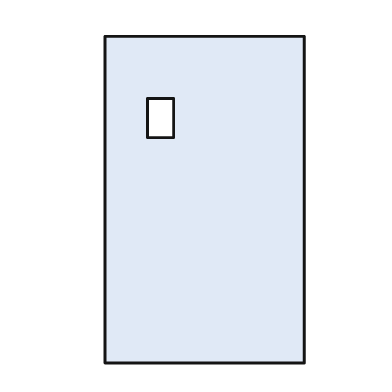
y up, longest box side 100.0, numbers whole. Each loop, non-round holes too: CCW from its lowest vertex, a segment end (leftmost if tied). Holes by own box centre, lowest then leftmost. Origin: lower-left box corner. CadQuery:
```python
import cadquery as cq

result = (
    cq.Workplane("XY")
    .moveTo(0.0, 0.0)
    .lineTo(61.0, 0.0)
    .lineTo(61.0, 100.0)
    .lineTo(0.0, 100.0)
    .close()
    .moveTo(13.0, 69.0)
    .lineTo(21.0, 69.0)
    .lineTo(21.0, 81.0)
    .lineTo(13.0, 81.0)
    .close()
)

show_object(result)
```